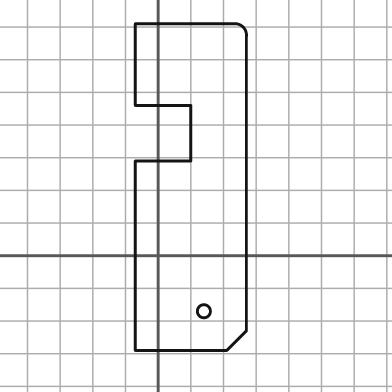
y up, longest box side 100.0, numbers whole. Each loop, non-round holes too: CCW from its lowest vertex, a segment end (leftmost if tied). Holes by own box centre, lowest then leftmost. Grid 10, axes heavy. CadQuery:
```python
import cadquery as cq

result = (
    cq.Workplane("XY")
    .moveTo(-7.0, -29.0)
    .lineTo(21.0, -29.0)
    .lineTo(27.0, -23.0)
    .lineTo(27.0, 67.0)
    .threePointArc((26.0, 70.0), (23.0, 71.0))
    .lineTo(-7.0, 71.0)
    .lineTo(-7.0, 46.0)
    .lineTo(10.0, 46.0)
    .lineTo(10.0, 29.0)
    .lineTo(-7.0, 29.0)
    .close()
    .moveTo(14.0, -17.0)
    .circle(2.0)
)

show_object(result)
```